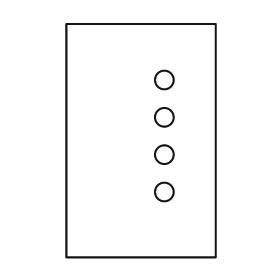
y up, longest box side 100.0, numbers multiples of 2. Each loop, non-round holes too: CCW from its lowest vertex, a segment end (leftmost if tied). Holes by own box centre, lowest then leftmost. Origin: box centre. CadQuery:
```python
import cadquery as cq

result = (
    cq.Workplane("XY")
    .moveTo(-32.0, -50.0)
    .lineTo(32.0, -50.0)
    .lineTo(32.0, 50.0)
    .lineTo(-32.0, 50.0)
    .close()
    .moveTo(10.0, -22.0)
    .circle(4.0)
    .moveTo(10.0, -6.0)
    .circle(4.0)
    .moveTo(10.0, 10.0)
    .circle(4.0)
    .moveTo(10.0, 26.0)
    .circle(4.0)
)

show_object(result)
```